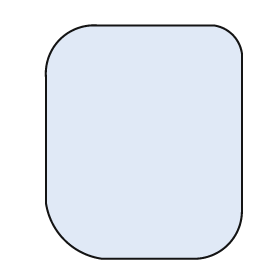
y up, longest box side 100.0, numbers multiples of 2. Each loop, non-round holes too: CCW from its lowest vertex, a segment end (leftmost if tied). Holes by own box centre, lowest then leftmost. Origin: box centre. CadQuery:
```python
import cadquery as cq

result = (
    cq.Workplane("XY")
    .moveTo(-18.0, -50.0)
    .lineTo(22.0, -50.0)
    .threePointArc((36.0, -44.0), (42.0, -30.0))
    .lineTo(42.0, 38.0)
    .threePointArc((38.0, 46.0), (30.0, 50.0))
    .lineTo(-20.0, 50.0)
    .threePointArc((-36.0, 44.0), (-42.0, 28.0))
    .lineTo(-42.0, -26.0)
    .threePointArc((-34.0, -42.0), (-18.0, -50.0))
    .close()
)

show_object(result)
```